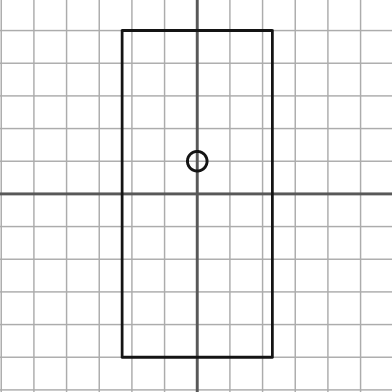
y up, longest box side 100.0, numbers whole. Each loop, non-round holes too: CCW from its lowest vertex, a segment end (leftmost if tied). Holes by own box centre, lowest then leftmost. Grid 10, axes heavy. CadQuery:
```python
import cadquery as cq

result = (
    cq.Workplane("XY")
    .moveTo(-23.0, -50.0)
    .lineTo(23.0, -50.0)
    .lineTo(23.0, 50.0)
    .lineTo(-23.0, 50.0)
    .close()
    .moveTo(0.0, 10.0)
    .circle(3.0)
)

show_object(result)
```